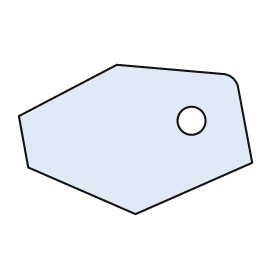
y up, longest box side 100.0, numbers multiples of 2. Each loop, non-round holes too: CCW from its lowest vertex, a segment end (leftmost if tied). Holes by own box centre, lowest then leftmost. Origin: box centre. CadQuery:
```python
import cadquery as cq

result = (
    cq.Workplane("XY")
    .moveTo(0.0, -32.0)
    .lineTo(50.0, -10.0)
    .lineTo(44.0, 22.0)
    .threePointArc((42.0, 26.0), (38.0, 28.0))
    .lineTo(-8.0, 32.0)
    .lineTo(-50.0, 10.0)
    .lineTo(-46.0, -12.0)
    .close()
    .moveTo(24.0, 8.0)
    .circle(6.0)
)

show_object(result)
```